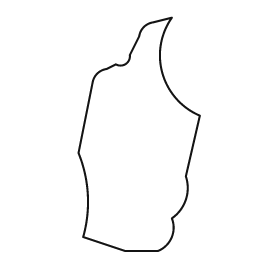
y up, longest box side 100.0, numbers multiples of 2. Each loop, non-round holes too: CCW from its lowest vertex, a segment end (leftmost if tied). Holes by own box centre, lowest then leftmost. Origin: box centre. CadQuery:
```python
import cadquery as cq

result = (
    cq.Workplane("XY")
    .moveTo(-6.0, -50.0)
    .lineTo(8.0, -50.0)
    .threePointArc((14.0, -44.0), (14.0, -36.0))
    .threePointArc((20.0, -28.0), (20.0, -18.0))
    .lineTo(26.0, 8.0)
    .threePointArc((10.0, 26.0), (14.0, 50.0))
    .lineTo(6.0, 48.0)
    .threePointArc((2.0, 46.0), (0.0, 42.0))
    .lineTo(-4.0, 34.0)
    .threePointArc((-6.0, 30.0), (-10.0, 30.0))
    .lineTo(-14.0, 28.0)
    .threePointArc((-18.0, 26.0), (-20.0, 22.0))
    .lineTo(-26.0, -8.0)
    .threePointArc((-22.0, -26.0), (-24.0, -44.0))
    .close()
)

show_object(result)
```